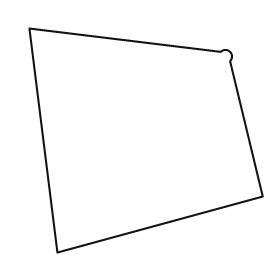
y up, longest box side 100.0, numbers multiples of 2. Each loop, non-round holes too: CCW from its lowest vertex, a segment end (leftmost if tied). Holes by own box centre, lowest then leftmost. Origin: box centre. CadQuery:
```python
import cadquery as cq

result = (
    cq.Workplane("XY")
    .moveTo(-38.0, -48.0)
    .lineTo(50.0, -24.0)
    .lineTo(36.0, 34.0)
    .threePointArc((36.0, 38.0), (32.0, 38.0))
    .lineTo(-50.0, 48.0)
    .close()
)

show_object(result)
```